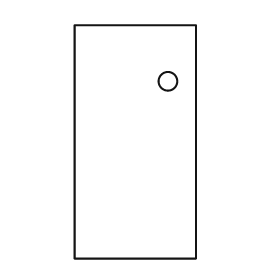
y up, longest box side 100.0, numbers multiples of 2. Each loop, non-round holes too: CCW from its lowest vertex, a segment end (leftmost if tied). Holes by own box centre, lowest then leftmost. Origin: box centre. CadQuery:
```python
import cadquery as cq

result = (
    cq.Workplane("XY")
    .moveTo(-26.0, -50.0)
    .lineTo(26.0, -50.0)
    .lineTo(26.0, 50.0)
    .lineTo(-26.0, 50.0)
    .close()
    .moveTo(14.0, 26.0)
    .circle(4.0)
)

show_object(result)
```